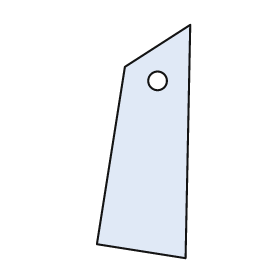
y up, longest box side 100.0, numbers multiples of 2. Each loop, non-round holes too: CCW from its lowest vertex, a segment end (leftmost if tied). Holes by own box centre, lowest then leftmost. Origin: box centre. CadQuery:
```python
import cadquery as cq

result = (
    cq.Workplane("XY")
    .moveTo(18.0, -50.0)
    .lineTo(20.0, 50.0)
    .lineTo(-8.0, 32.0)
    .lineTo(-20.0, -44.0)
    .close()
    .moveTo(6.0, 26.0)
    .circle(4.0)
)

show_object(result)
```